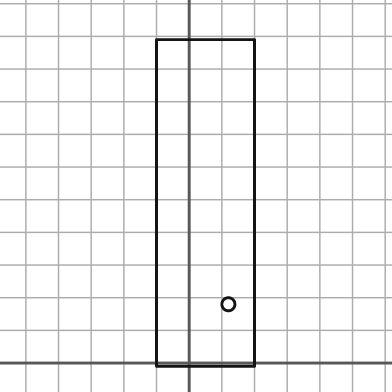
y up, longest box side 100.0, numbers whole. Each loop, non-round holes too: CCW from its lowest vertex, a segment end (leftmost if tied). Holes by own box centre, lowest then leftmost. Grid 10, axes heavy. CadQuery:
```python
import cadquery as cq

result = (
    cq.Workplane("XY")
    .moveTo(-10.0, -1.0)
    .lineTo(20.0, -1.0)
    .lineTo(20.0, 99.0)
    .lineTo(-10.0, 99.0)
    .close()
    .moveTo(12.0, 18.0)
    .circle(2.0)
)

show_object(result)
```